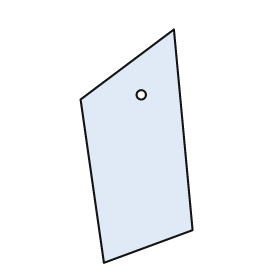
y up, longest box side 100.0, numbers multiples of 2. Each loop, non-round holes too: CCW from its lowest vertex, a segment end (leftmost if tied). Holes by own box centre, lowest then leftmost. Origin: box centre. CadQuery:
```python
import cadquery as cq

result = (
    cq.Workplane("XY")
    .moveTo(-14.0, -50.0)
    .lineTo(24.0, -36.0)
    .lineTo(16.0, 50.0)
    .lineTo(-24.0, 20.0)
    .close()
    .moveTo(2.0, 22.0)
    .circle(2.0)
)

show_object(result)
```